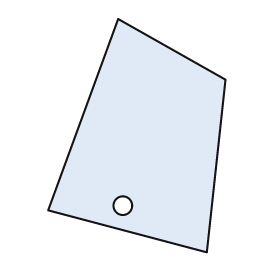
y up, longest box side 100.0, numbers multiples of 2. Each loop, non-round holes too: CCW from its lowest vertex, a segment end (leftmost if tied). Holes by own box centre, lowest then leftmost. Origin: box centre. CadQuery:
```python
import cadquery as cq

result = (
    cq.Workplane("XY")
    .moveTo(30.0, -50.0)
    .lineTo(38.0, 24.0)
    .lineTo(-8.0, 50.0)
    .lineTo(-38.0, -32.0)
    .close()
    .moveTo(-6.0, -30.0)
    .circle(4.0)
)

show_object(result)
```